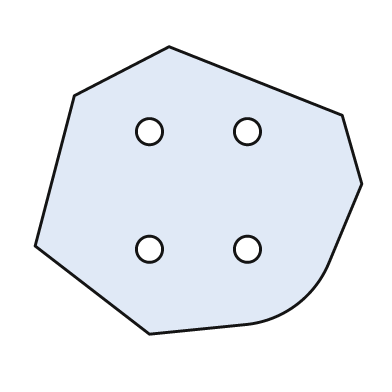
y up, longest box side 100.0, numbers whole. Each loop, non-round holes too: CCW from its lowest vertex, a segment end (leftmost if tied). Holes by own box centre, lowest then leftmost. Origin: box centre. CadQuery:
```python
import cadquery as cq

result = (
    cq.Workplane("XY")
    .moveTo(-15.0, -44.0)
    .lineTo(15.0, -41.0)
    .threePointArc((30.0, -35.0), (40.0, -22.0))
    .lineTo(50.0, 2.0)
    .lineTo(44.0, 23.0)
    .lineTo(-9.0, 44.0)
    .lineTo(-38.0, 29.0)
    .lineTo(-50.0, -17.0)
    .close()
    .moveTo(-15.0, -18.0)
    .circle(4.0)
    .moveTo(15.0, -18.0)
    .circle(4.0)
    .moveTo(-15.0, 18.0)
    .circle(4.0)
    .moveTo(15.0, 18.0)
    .circle(4.0)
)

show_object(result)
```